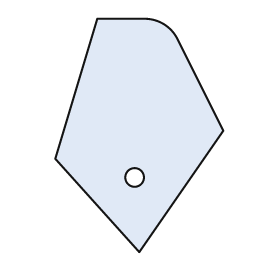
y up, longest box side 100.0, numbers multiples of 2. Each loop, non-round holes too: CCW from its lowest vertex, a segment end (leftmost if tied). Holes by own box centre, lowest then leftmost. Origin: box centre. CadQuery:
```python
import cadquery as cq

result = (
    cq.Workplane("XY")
    .moveTo(0.0, -50.0)
    .lineTo(36.0, 2.0)
    .lineTo(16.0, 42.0)
    .threePointArc((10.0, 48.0), (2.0, 50.0))
    .lineTo(-18.0, 50.0)
    .lineTo(-36.0, -10.0)
    .close()
    .moveTo(-2.0, -18.0)
    .circle(4.0)
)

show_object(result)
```